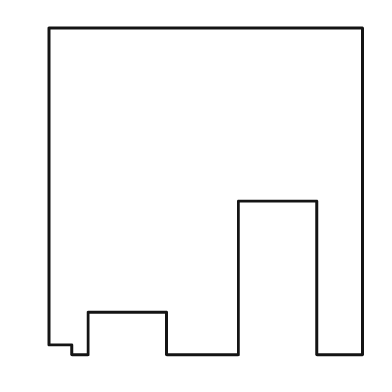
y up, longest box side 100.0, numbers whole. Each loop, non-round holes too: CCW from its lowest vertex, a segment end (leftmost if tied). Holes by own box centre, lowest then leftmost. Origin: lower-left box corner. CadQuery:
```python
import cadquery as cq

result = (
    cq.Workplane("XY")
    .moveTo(7.0, 0.0)
    .lineTo(12.0, 0.0)
    .lineTo(12.0, 13.0)
    .lineTo(36.0, 13.0)
    .lineTo(36.0, 0.0)
    .lineTo(58.0, 0.0)
    .lineTo(58.0, 47.0)
    .lineTo(82.0, 47.0)
    .lineTo(82.0, 0.0)
    .lineTo(96.0, 0.0)
    .lineTo(96.0, 100.0)
    .lineTo(0.0, 100.0)
    .lineTo(0.0, 3.0)
    .lineTo(7.0, 3.0)
    .close()
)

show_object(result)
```